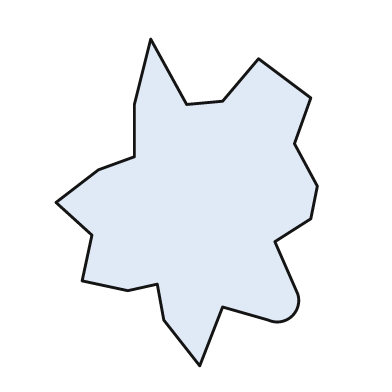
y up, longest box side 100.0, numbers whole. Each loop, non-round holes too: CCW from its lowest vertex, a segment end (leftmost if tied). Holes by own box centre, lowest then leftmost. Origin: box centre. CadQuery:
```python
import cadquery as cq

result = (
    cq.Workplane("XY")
    .moveTo(4.0, -50.0)
    .lineTo(11.0, -32.0)
    .lineTo(25.0, -36.0)
    .threePointArc((32.0, -35.0), (34.0, -28.0))
    .lineTo(27.0, -12.0)
    .lineTo(38.0, -5.0)
    .lineTo(40.0, 5.0)
    .lineTo(33.0, 18.0)
    .lineTo(38.0, 32.0)
    .lineTo(22.0, 44.0)
    .lineTo(11.0, 31.0)
    .lineTo(0.0, 30.0)
    .lineTo(-11.0, 50.0)
    .lineTo(-16.0, 30.0)
    .lineTo(-16.0, 14.0)
    .lineTo(-27.0, 10.0)
    .lineTo(-40.0, 0.0)
    .lineTo(-29.0, -10.0)
    .lineTo(-32.0, -24.0)
    .lineTo(-18.0, -27.0)
    .lineTo(-9.0, -25.0)
    .lineTo(-7.0, -36.0)
    .close()
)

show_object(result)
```